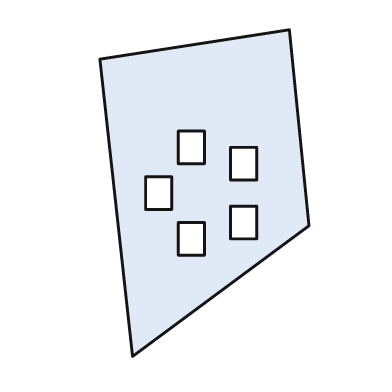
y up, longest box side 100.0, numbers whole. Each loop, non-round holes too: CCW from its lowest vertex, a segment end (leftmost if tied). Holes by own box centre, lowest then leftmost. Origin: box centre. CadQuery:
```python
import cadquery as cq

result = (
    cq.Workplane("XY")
    .moveTo(-22.0, -50.0)
    .lineTo(32.0, -10.0)
    .lineTo(26.0, 50.0)
    .lineTo(-32.0, 41.0)
    .close()
    .moveTo(-8.0, -19.0)
    .lineTo(0.0, -19.0)
    .lineTo(0.0, -9.0)
    .lineTo(-8.0, -9.0)
    .close()
    .moveTo(8.0, -14.0)
    .lineTo(16.0, -14.0)
    .lineTo(16.0, -4.0)
    .lineTo(8.0, -4.0)
    .close()
    .moveTo(-18.0, -5.0)
    .lineTo(-10.0, -5.0)
    .lineTo(-10.0, 5.0)
    .lineTo(-18.0, 5.0)
    .close()
    .moveTo(8.0, 4.0)
    .lineTo(16.0, 4.0)
    .lineTo(16.0, 14.0)
    .lineTo(8.0, 14.0)
    .close()
    .moveTo(-8.0, 9.0)
    .lineTo(0.0, 9.0)
    .lineTo(0.0, 19.0)
    .lineTo(-8.0, 19.0)
    .close()
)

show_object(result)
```